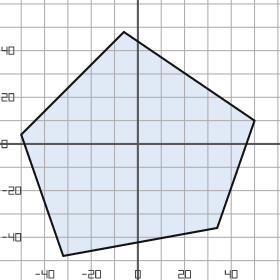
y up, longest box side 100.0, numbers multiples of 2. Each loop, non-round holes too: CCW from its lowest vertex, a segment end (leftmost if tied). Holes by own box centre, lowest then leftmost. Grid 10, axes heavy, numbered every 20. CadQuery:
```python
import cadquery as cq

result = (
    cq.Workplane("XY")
    .moveTo(-32.0, -48.0)
    .lineTo(34.0, -36.0)
    .lineTo(50.0, 10.0)
    .lineTo(-6.0, 48.0)
    .lineTo(-50.0, 4.0)
    .close()
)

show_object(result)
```